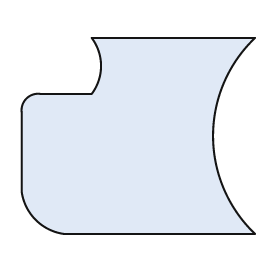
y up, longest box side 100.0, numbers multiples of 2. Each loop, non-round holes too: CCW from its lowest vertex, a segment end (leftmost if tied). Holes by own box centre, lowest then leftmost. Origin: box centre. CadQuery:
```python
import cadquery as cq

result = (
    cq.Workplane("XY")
    .moveTo(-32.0, -42.0)
    .lineTo(50.0, -42.0)
    .threePointArc((32.0, 0.0), (50.0, 42.0))
    .lineTo(-20.0, 42.0)
    .threePointArc((-16.0, 30.0), (-20.0, 18.0))
    .lineTo(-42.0, 18.0)
    .threePointArc((-48.0, 16.0), (-50.0, 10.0))
    .lineTo(-50.0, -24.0)
    .threePointArc((-44.0, -36.0), (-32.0, -42.0))
    .close()
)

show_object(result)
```